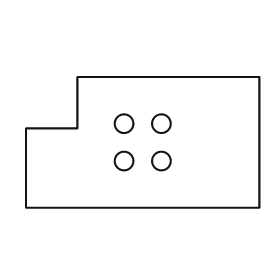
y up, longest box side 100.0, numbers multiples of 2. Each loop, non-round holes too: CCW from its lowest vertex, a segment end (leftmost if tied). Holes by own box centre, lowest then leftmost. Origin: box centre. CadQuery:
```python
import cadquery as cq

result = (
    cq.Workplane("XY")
    .moveTo(-50.0, -28.0)
    .lineTo(50.0, -28.0)
    .lineTo(50.0, 28.0)
    .lineTo(-28.0, 28.0)
    .lineTo(-28.0, 6.0)
    .lineTo(-50.0, 6.0)
    .close()
    .moveTo(-8.0, -8.0)
    .circle(4.0)
    .moveTo(8.0, -8.0)
    .circle(4.0)
    .moveTo(-8.0, 8.0)
    .circle(4.0)
    .moveTo(8.0, 8.0)
    .circle(4.0)
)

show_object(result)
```